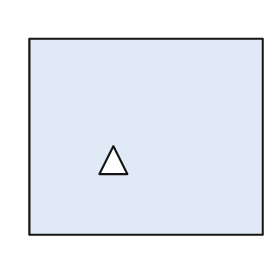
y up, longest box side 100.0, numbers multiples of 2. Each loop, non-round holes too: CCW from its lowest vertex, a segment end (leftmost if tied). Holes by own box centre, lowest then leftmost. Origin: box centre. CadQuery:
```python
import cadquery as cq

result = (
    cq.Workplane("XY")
    .moveTo(-50.0, -42.0)
    .lineTo(50.0, -42.0)
    .lineTo(50.0, 42.0)
    .lineTo(-50.0, 42.0)
    .close()
    .moveTo(-20.0, -16.0)
    .lineTo(-8.0, -16.0)
    .lineTo(-14.0, -4.0)
    .close()
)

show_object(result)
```